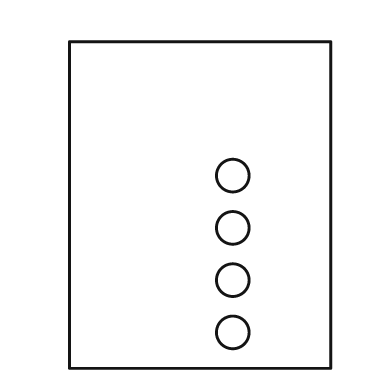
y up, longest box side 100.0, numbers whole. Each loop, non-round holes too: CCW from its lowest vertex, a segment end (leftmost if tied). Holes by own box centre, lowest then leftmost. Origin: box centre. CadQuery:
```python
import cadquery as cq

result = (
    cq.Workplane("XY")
    .moveTo(-40.0, -50.0)
    .lineTo(40.0, -50.0)
    .lineTo(40.0, 50.0)
    .lineTo(-40.0, 50.0)
    .close()
    .moveTo(10.0, -39.0)
    .circle(5.0)
    .moveTo(10.0, -23.0)
    .circle(5.0)
    .moveTo(10.0, -7.0)
    .circle(5.0)
    .moveTo(10.0, 9.0)
    .circle(5.0)
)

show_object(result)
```